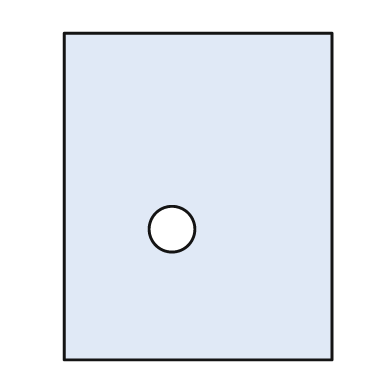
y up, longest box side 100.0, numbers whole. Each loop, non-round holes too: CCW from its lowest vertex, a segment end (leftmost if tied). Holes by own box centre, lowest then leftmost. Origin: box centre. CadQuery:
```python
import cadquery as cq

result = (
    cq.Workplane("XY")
    .moveTo(-41.0, -50.0)
    .lineTo(41.0, -50.0)
    .lineTo(41.0, 50.0)
    .lineTo(-41.0, 50.0)
    .close()
    .moveTo(-8.0, -10.0)
    .circle(7.0)
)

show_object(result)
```